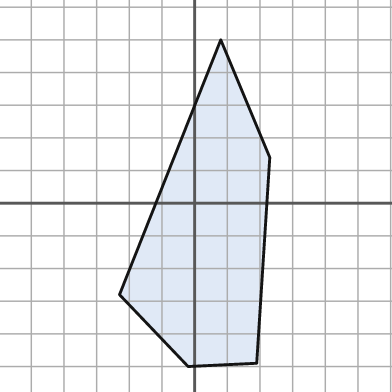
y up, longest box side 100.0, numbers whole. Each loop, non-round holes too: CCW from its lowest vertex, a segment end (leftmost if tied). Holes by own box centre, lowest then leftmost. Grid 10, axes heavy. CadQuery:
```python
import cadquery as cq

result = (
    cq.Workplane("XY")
    .moveTo(-2.0, -50.0)
    .lineTo(19.0, -49.0)
    .lineTo(23.0, 14.0)
    .lineTo(8.0, 50.0)
    .lineTo(-23.0, -28.0)
    .close()
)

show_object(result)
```